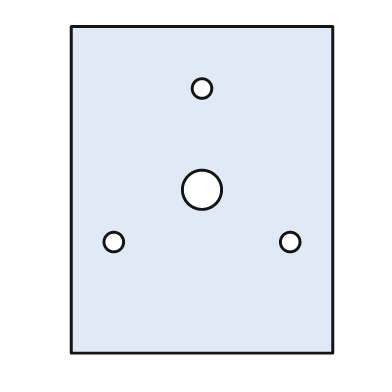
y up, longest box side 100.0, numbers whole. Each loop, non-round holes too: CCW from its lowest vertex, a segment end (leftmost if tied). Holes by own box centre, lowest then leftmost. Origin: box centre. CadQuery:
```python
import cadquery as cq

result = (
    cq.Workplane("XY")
    .moveTo(-40.0, -50.0)
    .lineTo(40.0, -50.0)
    .lineTo(40.0, 50.0)
    .lineTo(-40.0, 50.0)
    .close()
    .moveTo(-27.0, -16.0)
    .circle(3.0)
    .moveTo(27.0, -16.0)
    .circle(3.0)
    .moveTo(0.0, 0.0)
    .circle(6.0)
    .moveTo(0.0, 31.0)
    .circle(3.0)
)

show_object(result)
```